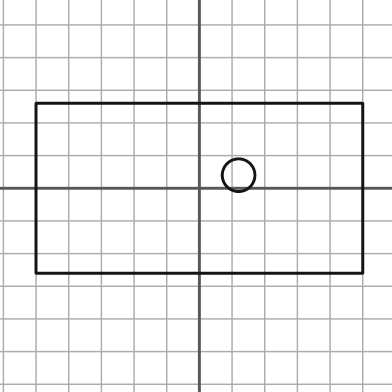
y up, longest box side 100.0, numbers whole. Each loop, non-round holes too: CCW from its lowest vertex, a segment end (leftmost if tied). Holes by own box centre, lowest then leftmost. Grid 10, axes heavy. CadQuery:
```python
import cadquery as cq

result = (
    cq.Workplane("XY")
    .moveTo(-50.0, -26.0)
    .lineTo(50.0, -26.0)
    .lineTo(50.0, 26.0)
    .lineTo(-50.0, 26.0)
    .close()
    .moveTo(12.0, 4.0)
    .circle(5.0)
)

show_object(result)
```